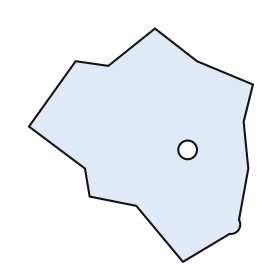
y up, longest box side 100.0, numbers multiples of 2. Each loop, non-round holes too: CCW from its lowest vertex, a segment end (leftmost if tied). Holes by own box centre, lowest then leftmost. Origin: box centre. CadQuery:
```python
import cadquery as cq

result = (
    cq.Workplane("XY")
    .moveTo(18.0, -50.0)
    .lineTo(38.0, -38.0)
    .threePointArc((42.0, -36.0), (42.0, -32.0))
    .lineTo(46.0, -10.0)
    .lineTo(44.0, 10.0)
    .lineTo(48.0, 26.0)
    .lineTo(24.0, 36.0)
    .lineTo(6.0, 50.0)
    .lineTo(-14.0, 34.0)
    .lineTo(-28.0, 36.0)
    .lineTo(-48.0, 8.0)
    .lineTo(-24.0, -10.0)
    .lineTo(-22.0, -22.0)
    .lineTo(-2.0, -26.0)
    .close()
    .moveTo(20.0, -2.0)
    .circle(4.0)
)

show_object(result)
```